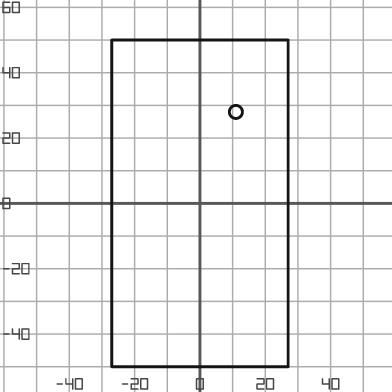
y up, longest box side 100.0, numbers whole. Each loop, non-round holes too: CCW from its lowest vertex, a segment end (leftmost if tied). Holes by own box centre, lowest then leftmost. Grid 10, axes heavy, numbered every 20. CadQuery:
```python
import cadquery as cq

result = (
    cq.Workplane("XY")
    .moveTo(-27.0, -50.0)
    .lineTo(27.0, -50.0)
    .lineTo(27.0, 50.0)
    .lineTo(-27.0, 50.0)
    .close()
    .moveTo(11.0, 28.0)
    .circle(2.0)
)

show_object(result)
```